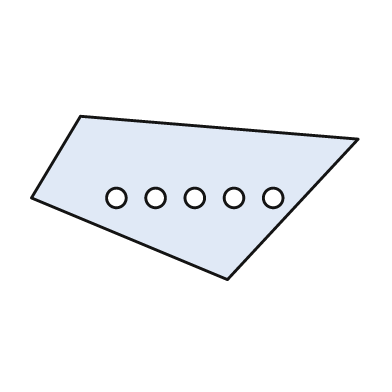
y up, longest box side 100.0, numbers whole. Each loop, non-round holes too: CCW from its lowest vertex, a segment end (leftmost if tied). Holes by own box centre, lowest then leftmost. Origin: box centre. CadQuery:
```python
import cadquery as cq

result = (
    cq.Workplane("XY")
    .moveTo(10.0, -25.0)
    .lineTo(50.0, 18.0)
    .lineTo(-35.0, 25.0)
    .lineTo(-50.0, 0.0)
    .close()
    .moveTo(-24.0, 0.0)
    .circle(3.0)
    .moveTo(-12.0, 0.0)
    .circle(3.0)
    .moveTo(0.0, 0.0)
    .circle(3.0)
    .moveTo(12.0, 0.0)
    .circle(3.0)
    .moveTo(24.0, 0.0)
    .circle(3.0)
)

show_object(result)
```